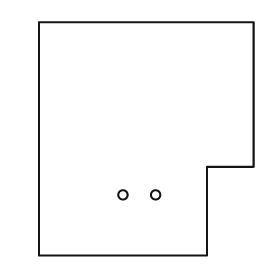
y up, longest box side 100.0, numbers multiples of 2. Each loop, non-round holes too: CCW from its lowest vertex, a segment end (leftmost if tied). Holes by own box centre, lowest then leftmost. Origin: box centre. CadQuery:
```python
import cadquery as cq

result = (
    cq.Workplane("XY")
    .moveTo(-46.0, -50.0)
    .lineTo(26.0, -50.0)
    .lineTo(26.0, -12.0)
    .lineTo(46.0, -12.0)
    .lineTo(46.0, 50.0)
    .lineTo(-46.0, 50.0)
    .close()
    .moveTo(-10.0, -24.0)
    .circle(2.0)
    .moveTo(4.0, -24.0)
    .circle(2.0)
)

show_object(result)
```